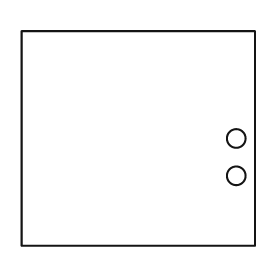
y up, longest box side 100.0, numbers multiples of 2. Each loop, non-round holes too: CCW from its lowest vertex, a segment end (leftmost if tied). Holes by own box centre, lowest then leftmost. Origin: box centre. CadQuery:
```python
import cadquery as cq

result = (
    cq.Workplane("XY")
    .moveTo(-50.0, -46.0)
    .lineTo(50.0, -46.0)
    .lineTo(50.0, 46.0)
    .lineTo(-50.0, 46.0)
    .close()
    .moveTo(42.0, -16.0)
    .circle(4.0)
    .moveTo(42.0, 0.0)
    .circle(4.0)
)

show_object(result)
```